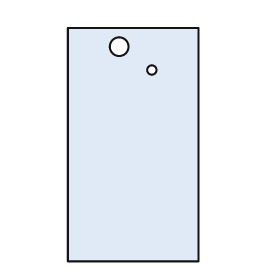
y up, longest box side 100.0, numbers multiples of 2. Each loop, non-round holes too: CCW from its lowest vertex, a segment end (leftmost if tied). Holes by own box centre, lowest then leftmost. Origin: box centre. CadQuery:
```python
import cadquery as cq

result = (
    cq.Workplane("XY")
    .moveTo(-28.0, -50.0)
    .lineTo(28.0, -50.0)
    .lineTo(28.0, 50.0)
    .lineTo(-28.0, 50.0)
    .close()
    .moveTo(8.0, 32.0)
    .circle(2.0)
    .moveTo(-6.0, 42.0)
    .circle(4.0)
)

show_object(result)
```